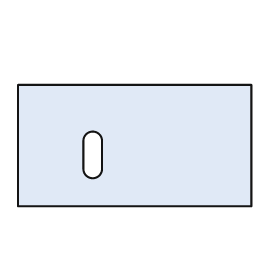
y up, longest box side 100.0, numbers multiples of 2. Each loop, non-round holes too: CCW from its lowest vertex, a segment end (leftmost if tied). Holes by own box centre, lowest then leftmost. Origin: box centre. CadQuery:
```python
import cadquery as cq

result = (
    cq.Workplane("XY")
    .moveTo(-50.0, -26.0)
    .lineTo(50.0, -26.0)
    .lineTo(50.0, 26.0)
    .lineTo(-50.0, 26.0)
    .close()
    .moveTo(-22.0, -10.0)
    .threePointArc((-18.0, -14.0), (-14.0, -10.0))
    .lineTo(-14.0, 2.0)
    .threePointArc((-18.0, 6.0), (-22.0, 2.0))
    .close()
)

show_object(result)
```